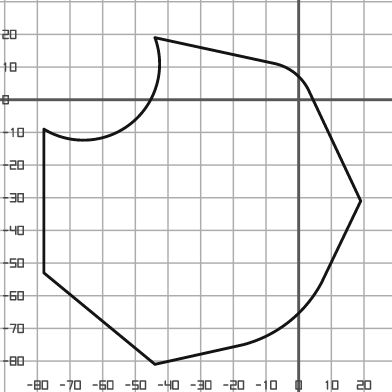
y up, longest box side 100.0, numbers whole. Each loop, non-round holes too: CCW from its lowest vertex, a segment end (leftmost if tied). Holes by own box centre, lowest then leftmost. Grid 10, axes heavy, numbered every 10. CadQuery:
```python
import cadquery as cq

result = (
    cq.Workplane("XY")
    .moveTo(-44.0, -81.0)
    .lineTo(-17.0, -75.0)
    .threePointArc((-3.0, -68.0), (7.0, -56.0))
    .lineTo(19.0, -31.0)
    .lineTo(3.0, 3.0)
    .threePointArc((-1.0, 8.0), (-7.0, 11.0))
    .lineTo(-44.0, 19.0)
    .threePointArc((-51.0, -7.0), (-78.0, -9.0))
    .lineTo(-78.0, -53.0)
    .close()
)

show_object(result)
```